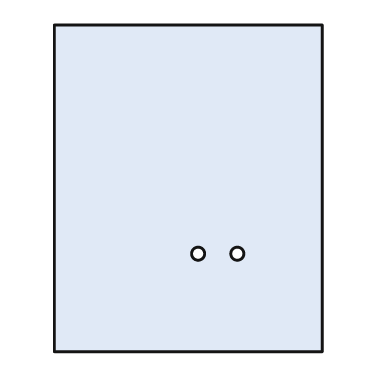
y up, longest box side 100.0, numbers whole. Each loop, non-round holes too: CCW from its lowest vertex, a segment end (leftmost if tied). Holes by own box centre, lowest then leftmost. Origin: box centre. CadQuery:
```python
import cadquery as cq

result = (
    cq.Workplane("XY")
    .moveTo(-41.0, -50.0)
    .lineTo(41.0, -50.0)
    .lineTo(41.0, 50.0)
    .lineTo(-41.0, 50.0)
    .close()
    .moveTo(3.0, -20.0)
    .circle(2.0)
    .moveTo(15.0, -20.0)
    .circle(2.0)
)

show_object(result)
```